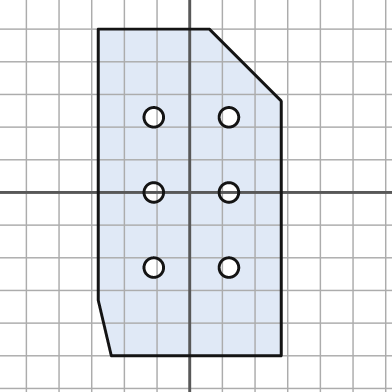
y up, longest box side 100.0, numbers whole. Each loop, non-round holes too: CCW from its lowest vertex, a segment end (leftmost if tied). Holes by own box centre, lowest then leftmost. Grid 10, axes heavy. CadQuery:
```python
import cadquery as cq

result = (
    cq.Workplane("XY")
    .moveTo(-24.0, -50.0)
    .lineTo(28.0, -50.0)
    .lineTo(28.0, 28.0)
    .lineTo(6.0, 50.0)
    .lineTo(-28.0, 50.0)
    .lineTo(-28.0, -33.0)
    .close()
    .moveTo(-11.0, -23.0)
    .circle(3.0)
    .moveTo(12.0, -23.0)
    .circle(3.0)
    .moveTo(-11.0, 0.0)
    .circle(3.0)
    .moveTo(12.0, 0.0)
    .circle(3.0)
    .moveTo(-11.0, 23.0)
    .circle(3.0)
    .moveTo(12.0, 23.0)
    .circle(3.0)
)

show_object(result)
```